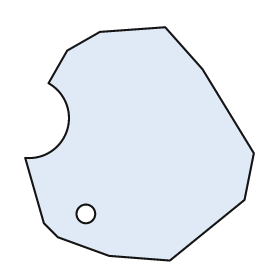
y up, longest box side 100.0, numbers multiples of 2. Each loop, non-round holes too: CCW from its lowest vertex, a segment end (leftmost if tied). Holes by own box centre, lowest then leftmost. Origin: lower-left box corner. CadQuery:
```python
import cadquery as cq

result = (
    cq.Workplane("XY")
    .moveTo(62.0, 0.0)
    .lineTo(94.0, 26.0)
    .lineTo(98.0, 46.0)
    .lineTo(76.0, 82.0)
    .lineTo(60.0, 100.0)
    .lineTo(32.0, 98.0)
    .lineTo(18.0, 90.0)
    .lineTo(10.0, 76.0)
    .threePointArc((18.0, 56.0), (0.0, 44.0))
    .lineTo(8.0, 16.0)
    .lineTo(14.0, 10.0)
    .lineTo(36.0, 2.0)
    .close()
    .moveTo(26.0, 20.0)
    .circle(4.0)
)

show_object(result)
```